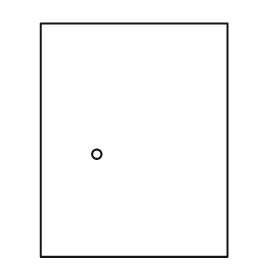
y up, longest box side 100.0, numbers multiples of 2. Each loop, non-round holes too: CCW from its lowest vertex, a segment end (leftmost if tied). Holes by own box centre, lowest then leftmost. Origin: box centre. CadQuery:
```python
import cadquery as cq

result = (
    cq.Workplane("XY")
    .moveTo(-40.0, -50.0)
    .lineTo(40.0, -50.0)
    .lineTo(40.0, 50.0)
    .lineTo(-40.0, 50.0)
    .close()
    .moveTo(-16.0, -6.0)
    .circle(2.0)
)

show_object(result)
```